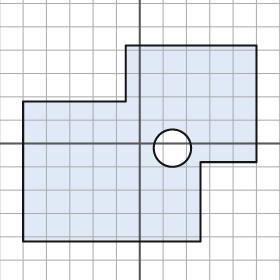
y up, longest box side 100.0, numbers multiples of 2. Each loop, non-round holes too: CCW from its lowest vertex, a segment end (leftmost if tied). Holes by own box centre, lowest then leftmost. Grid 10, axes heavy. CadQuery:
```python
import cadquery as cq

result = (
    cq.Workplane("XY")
    .moveTo(-50.0, -42.0)
    .lineTo(26.0, -42.0)
    .lineTo(26.0, -8.0)
    .lineTo(50.0, -8.0)
    .lineTo(50.0, 42.0)
    .lineTo(-6.0, 42.0)
    .lineTo(-6.0, 18.0)
    .lineTo(-50.0, 18.0)
    .close()
    .moveTo(14.0, -2.0)
    .circle(8.0)
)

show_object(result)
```